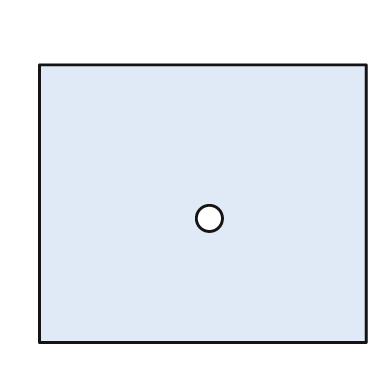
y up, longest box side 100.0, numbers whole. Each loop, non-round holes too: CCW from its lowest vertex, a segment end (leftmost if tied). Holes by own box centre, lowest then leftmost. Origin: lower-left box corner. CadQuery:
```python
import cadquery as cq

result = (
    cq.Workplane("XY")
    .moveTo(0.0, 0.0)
    .lineTo(100.0, 0.0)
    .lineTo(100.0, 85.0)
    .lineTo(0.0, 85.0)
    .close()
    .moveTo(52.0, 38.0)
    .circle(4.0)
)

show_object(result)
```